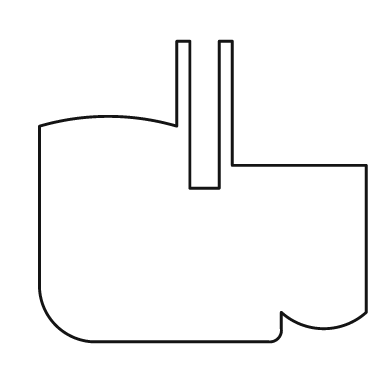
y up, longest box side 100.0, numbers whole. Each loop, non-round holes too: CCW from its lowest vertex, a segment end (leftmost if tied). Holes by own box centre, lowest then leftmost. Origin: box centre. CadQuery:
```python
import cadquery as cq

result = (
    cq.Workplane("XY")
    .moveTo(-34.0, -46.0)
    .lineTo(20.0, -46.0)
    .threePointArc((23.0, -45.0), (24.0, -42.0))
    .lineTo(24.0, -37.0)
    .threePointArc((37.0, -42.0), (50.0, -37.0))
    .lineTo(50.0, 8.0)
    .lineTo(9.0, 8.0)
    .lineTo(9.0, 46.0)
    .lineTo(5.0, 46.0)
    .lineTo(5.0, 1.0)
    .lineTo(-4.0, 1.0)
    .lineTo(-4.0, 46.0)
    .lineTo(-8.0, 46.0)
    .lineTo(-8.0, 20.0)
    .threePointArc((-29.0, 23.0), (-50.0, 20.0))
    .lineTo(-50.0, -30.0)
    .threePointArc((-45.0, -41.0), (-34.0, -46.0))
    .close()
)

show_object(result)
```